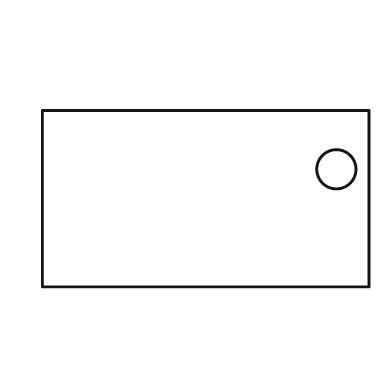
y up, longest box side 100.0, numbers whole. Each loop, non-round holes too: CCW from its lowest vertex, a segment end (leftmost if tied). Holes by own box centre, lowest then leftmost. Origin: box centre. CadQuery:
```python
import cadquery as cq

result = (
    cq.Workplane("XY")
    .moveTo(-50.0, -27.0)
    .lineTo(50.0, -27.0)
    .lineTo(50.0, 27.0)
    .lineTo(-50.0, 27.0)
    .close()
    .moveTo(40.0, 9.0)
    .circle(6.0)
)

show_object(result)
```